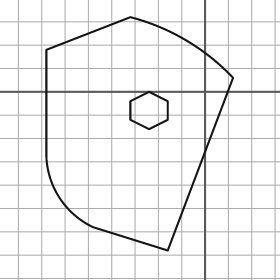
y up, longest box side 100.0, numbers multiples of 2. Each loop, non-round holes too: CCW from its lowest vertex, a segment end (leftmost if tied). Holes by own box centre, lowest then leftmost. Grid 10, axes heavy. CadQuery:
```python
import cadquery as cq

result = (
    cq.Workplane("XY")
    .moveTo(-16.0, -68.0)
    .lineTo(12.0, 6.0)
    .threePointArc((-8.0, 22.0), (-32.0, 32.0))
    .lineTo(-68.0, 18.0)
    .lineTo(-68.0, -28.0)
    .threePointArc((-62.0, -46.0), (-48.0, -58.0))
    .close()
    .moveTo(-24.0, -16.0)
    .lineTo(-16.0, -12.0)
    .lineTo(-16.0, -4.0)
    .lineTo(-24.0, 0.0)
    .lineTo(-32.0, -4.0)
    .lineTo(-32.0, -12.0)
    .close()
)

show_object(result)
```